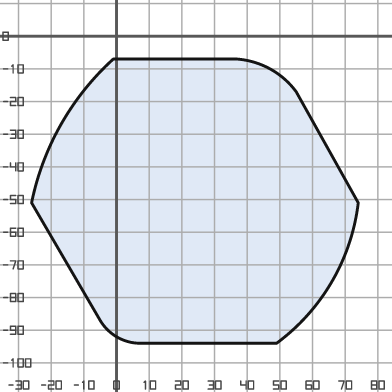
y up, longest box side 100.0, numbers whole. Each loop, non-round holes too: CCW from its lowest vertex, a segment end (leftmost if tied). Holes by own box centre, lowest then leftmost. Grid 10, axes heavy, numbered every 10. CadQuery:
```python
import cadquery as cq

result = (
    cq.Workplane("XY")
    .moveTo(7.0, -94.0)
    .lineTo(49.0, -94.0)
    .threePointArc((66.0, -75.0), (74.0, -51.0))
    .lineTo(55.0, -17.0)
    .threePointArc((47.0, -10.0), (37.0, -7.0))
    .lineTo(-1.0, -7.0)
    .threePointArc((-17.0, -27.0), (-26.0, -51.0))
    .lineTo(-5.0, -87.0)
    .threePointArc((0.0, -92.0), (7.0, -94.0))
    .close()
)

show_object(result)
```